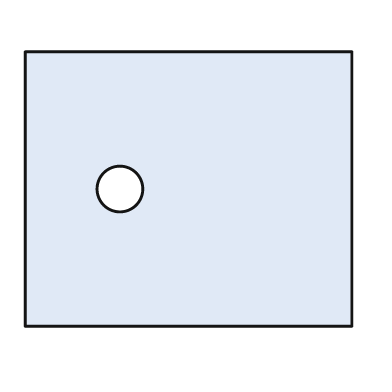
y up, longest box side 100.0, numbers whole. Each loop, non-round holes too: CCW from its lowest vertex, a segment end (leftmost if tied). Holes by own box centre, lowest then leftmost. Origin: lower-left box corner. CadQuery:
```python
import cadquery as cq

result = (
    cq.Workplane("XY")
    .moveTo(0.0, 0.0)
    .lineTo(100.0, 0.0)
    .lineTo(100.0, 84.0)
    .lineTo(0.0, 84.0)
    .close()
    .moveTo(29.0, 42.0)
    .circle(7.0)
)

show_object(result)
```